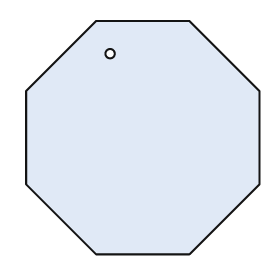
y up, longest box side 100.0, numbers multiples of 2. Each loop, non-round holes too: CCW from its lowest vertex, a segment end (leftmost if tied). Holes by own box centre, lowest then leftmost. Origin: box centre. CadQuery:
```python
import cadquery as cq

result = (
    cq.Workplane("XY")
    .moveTo(-20.0, -50.0)
    .lineTo(20.0, -50.0)
    .lineTo(50.0, -20.0)
    .lineTo(50.0, 20.0)
    .lineTo(20.0, 50.0)
    .lineTo(-20.0, 50.0)
    .lineTo(-50.0, 20.0)
    .lineTo(-50.0, -20.0)
    .close()
    .moveTo(-14.0, 36.0)
    .circle(2.0)
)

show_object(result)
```